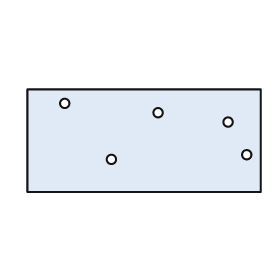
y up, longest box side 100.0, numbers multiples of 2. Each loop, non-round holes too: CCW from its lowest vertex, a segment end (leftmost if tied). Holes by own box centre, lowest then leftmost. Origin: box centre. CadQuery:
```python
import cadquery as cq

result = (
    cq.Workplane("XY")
    .moveTo(-50.0, -22.0)
    .lineTo(50.0, -22.0)
    .lineTo(50.0, 22.0)
    .lineTo(-50.0, 22.0)
    .close()
    .moveTo(-14.0, -8.0)
    .circle(2.0)
    .moveTo(44.0, -6.0)
    .circle(2.0)
    .moveTo(36.0, 8.0)
    .circle(2.0)
    .moveTo(6.0, 12.0)
    .circle(2.0)
    .moveTo(-34.0, 16.0)
    .circle(2.0)
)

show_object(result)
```